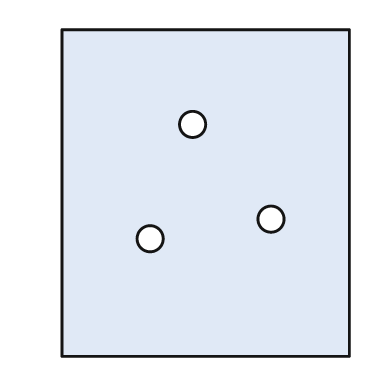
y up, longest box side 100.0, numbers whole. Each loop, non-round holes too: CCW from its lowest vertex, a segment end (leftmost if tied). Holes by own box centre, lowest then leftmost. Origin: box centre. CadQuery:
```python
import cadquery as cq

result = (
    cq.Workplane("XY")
    .moveTo(-44.0, -50.0)
    .lineTo(44.0, -50.0)
    .lineTo(44.0, 50.0)
    .lineTo(-44.0, 50.0)
    .close()
    .moveTo(-17.0, -14.0)
    .circle(4.0)
    .moveTo(20.0, -8.0)
    .circle(4.0)
    .moveTo(-4.0, 21.0)
    .circle(4.0)
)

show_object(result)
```